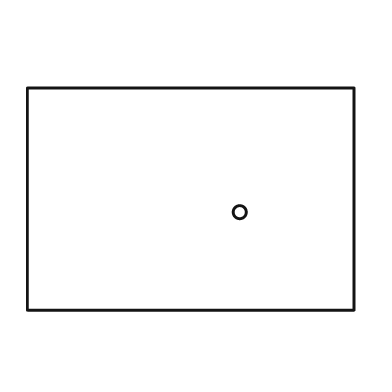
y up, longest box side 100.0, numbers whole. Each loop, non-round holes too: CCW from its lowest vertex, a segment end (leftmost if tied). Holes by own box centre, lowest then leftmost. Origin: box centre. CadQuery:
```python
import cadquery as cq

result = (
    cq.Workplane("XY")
    .moveTo(-50.0, -34.0)
    .lineTo(50.0, -34.0)
    .lineTo(50.0, 34.0)
    .lineTo(-50.0, 34.0)
    .close()
    .moveTo(15.0, -4.0)
    .circle(2.0)
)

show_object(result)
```